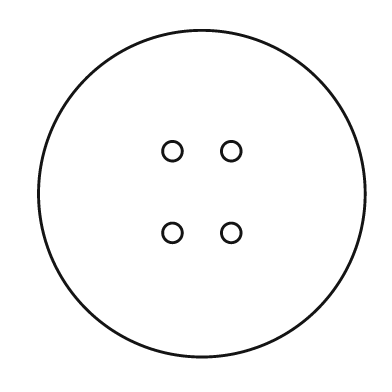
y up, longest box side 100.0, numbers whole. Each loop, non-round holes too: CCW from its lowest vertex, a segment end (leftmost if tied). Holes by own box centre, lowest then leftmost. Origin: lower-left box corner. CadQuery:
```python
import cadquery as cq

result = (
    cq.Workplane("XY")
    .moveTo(50.0, 50.0)
    .circle(50.0)
    .moveTo(41.0, 38.0)
    .circle(3.0)
    .moveTo(59.0, 38.0)
    .circle(3.0)
    .moveTo(41.0, 63.0)
    .circle(3.0)
    .moveTo(59.0, 63.0)
    .circle(3.0)
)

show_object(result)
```